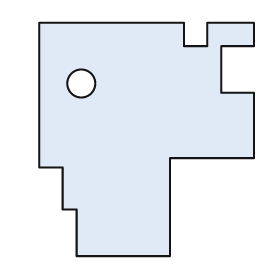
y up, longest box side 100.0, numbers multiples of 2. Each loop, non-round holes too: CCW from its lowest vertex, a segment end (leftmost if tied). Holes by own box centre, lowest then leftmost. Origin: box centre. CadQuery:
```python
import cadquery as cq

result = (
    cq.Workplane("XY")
    .moveTo(-30.0, -50.0)
    .lineTo(10.0, -50.0)
    .lineTo(10.0, -8.0)
    .lineTo(46.0, -8.0)
    .lineTo(46.0, 20.0)
    .lineTo(32.0, 20.0)
    .lineTo(32.0, 40.0)
    .lineTo(46.0, 40.0)
    .lineTo(46.0, 50.0)
    .lineTo(26.0, 50.0)
    .lineTo(26.0, 40.0)
    .lineTo(16.0, 40.0)
    .lineTo(16.0, 50.0)
    .lineTo(-46.0, 50.0)
    .lineTo(-46.0, -12.0)
    .lineTo(-36.0, -12.0)
    .lineTo(-36.0, -30.0)
    .lineTo(-30.0, -30.0)
    .close()
    .moveTo(-28.0, 24.0)
    .circle(6.0)
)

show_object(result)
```